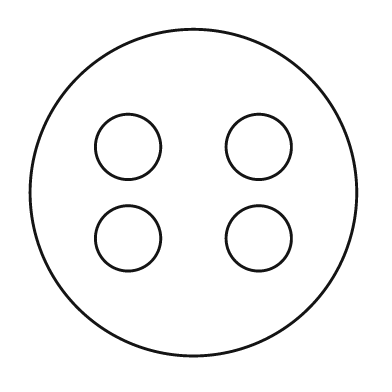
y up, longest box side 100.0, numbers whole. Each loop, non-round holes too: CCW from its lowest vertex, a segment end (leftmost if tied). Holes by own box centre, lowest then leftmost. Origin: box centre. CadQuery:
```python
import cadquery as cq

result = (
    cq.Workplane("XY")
    .moveTo(0.0, 0.0)
    .circle(50.0)
    .moveTo(-20.0, -14.0)
    .circle(10.0)
    .moveTo(20.0, -14.0)
    .circle(10.0)
    .moveTo(-20.0, 14.0)
    .circle(10.0)
    .moveTo(20.0, 14.0)
    .circle(10.0)
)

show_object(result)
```